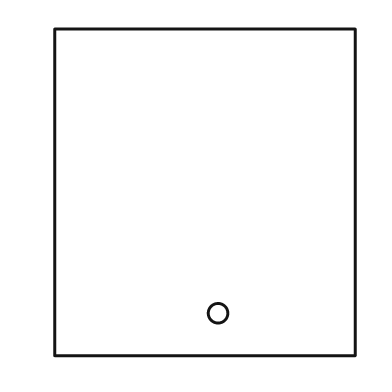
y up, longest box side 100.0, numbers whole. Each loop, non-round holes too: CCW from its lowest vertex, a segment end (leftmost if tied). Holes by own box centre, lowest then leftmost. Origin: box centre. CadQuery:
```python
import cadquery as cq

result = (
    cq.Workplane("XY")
    .moveTo(-46.0, -50.0)
    .lineTo(46.0, -50.0)
    .lineTo(46.0, 50.0)
    .lineTo(-46.0, 50.0)
    .close()
    .moveTo(4.0, -37.0)
    .circle(3.0)
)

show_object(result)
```